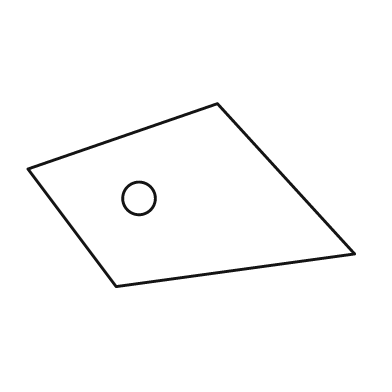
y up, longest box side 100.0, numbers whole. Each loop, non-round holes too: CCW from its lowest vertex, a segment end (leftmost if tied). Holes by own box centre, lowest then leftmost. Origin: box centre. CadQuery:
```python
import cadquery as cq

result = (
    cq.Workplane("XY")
    .moveTo(-23.0, -28.0)
    .lineTo(50.0, -18.0)
    .lineTo(8.0, 28.0)
    .lineTo(-50.0, 8.0)
    .close()
    .moveTo(-16.0, -1.0)
    .circle(5.0)
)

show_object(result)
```